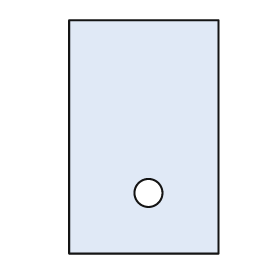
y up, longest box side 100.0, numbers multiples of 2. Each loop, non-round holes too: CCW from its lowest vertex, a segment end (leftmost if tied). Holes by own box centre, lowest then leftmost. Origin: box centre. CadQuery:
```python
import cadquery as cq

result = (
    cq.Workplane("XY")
    .moveTo(-32.0, -50.0)
    .lineTo(32.0, -50.0)
    .lineTo(32.0, 50.0)
    .lineTo(-32.0, 50.0)
    .close()
    .moveTo(2.0, -24.0)
    .circle(6.0)
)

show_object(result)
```